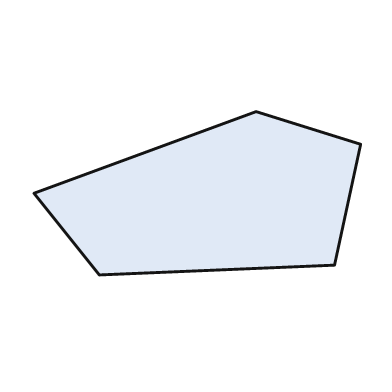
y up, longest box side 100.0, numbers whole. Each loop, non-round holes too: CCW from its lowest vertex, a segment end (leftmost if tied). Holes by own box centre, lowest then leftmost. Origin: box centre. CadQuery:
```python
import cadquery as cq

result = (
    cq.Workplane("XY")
    .moveTo(-30.0, -25.0)
    .lineTo(42.0, -22.0)
    .lineTo(50.0, 15.0)
    .lineTo(18.0, 25.0)
    .lineTo(-50.0, 0.0)
    .close()
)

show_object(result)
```